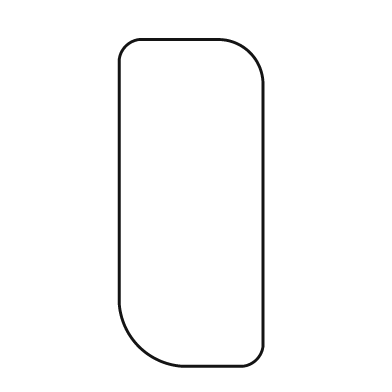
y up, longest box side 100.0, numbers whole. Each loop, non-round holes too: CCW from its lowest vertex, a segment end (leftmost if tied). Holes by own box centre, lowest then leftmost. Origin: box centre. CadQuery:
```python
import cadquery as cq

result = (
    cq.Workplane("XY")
    .moveTo(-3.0, -50.0)
    .lineTo(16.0, -50.0)
    .threePointArc((20.0, -48.0), (22.0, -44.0))
    .lineTo(22.0, 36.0)
    .threePointArc((18.0, 46.0), (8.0, 50.0))
    .lineTo(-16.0, 50.0)
    .threePointArc((-20.0, 48.0), (-22.0, 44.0))
    .lineTo(-22.0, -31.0)
    .threePointArc((-16.0, -44.0), (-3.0, -50.0))
    .close()
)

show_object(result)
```